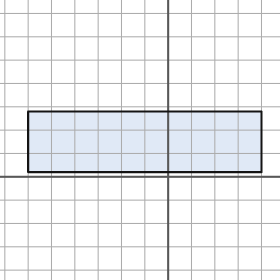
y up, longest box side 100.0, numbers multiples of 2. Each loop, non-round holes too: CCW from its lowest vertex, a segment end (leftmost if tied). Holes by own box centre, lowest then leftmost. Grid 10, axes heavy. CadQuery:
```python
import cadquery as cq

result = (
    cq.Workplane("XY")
    .moveTo(-60.0, 2.0)
    .lineTo(40.0, 2.0)
    .lineTo(40.0, 28.0)
    .lineTo(-60.0, 28.0)
    .close()
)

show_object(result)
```